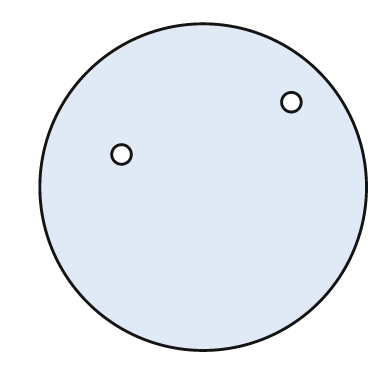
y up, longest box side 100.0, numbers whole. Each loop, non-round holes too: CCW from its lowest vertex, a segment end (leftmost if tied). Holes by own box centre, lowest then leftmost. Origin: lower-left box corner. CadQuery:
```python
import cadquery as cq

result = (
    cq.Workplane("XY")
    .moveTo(50.0, 50.0)
    .circle(50.0)
    .moveTo(25.0, 60.0)
    .circle(3.0)
    .moveTo(77.0, 76.0)
    .circle(3.0)
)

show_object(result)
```